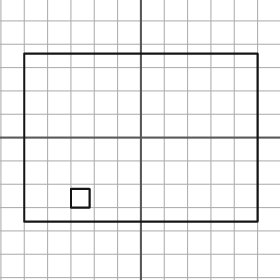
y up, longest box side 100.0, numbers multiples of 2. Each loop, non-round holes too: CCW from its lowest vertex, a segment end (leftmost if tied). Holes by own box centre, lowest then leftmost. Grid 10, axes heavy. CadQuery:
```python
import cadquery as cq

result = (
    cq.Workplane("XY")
    .moveTo(-50.0, -36.0)
    .lineTo(50.0, -36.0)
    .lineTo(50.0, 36.0)
    .lineTo(-50.0, 36.0)
    .close()
    .moveTo(-30.0, -30.0)
    .lineTo(-22.0, -30.0)
    .lineTo(-22.0, -22.0)
    .lineTo(-30.0, -22.0)
    .close()
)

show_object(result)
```